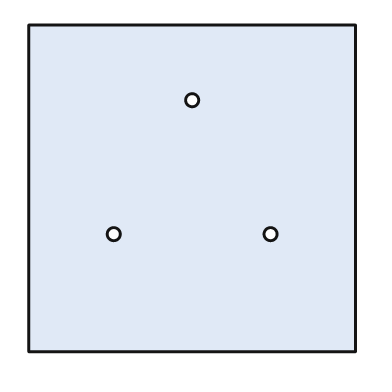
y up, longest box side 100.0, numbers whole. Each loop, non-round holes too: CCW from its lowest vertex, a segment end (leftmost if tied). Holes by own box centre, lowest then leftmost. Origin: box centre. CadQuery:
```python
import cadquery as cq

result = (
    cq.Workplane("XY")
    .moveTo(-50.0, -50.0)
    .lineTo(50.0, -50.0)
    .lineTo(50.0, 50.0)
    .lineTo(-50.0, 50.0)
    .close()
    .moveTo(-24.0, -14.0)
    .circle(2.0)
    .moveTo(24.0, -14.0)
    .circle(2.0)
    .moveTo(0.0, 27.0)
    .circle(2.0)
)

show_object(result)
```